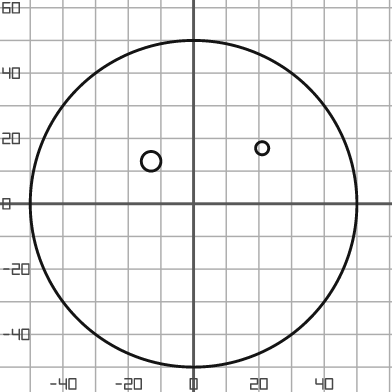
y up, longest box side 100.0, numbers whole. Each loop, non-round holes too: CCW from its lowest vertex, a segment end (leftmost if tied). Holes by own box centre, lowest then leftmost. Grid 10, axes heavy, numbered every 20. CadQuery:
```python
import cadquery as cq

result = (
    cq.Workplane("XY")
    .moveTo(0.0, 0.0)
    .circle(50.0)
    .moveTo(-13.0, 13.0)
    .circle(3.0)
    .moveTo(21.0, 17.0)
    .circle(2.0)
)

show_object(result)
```